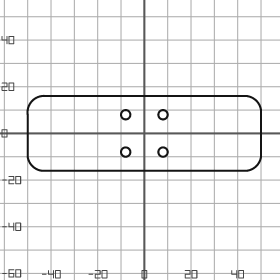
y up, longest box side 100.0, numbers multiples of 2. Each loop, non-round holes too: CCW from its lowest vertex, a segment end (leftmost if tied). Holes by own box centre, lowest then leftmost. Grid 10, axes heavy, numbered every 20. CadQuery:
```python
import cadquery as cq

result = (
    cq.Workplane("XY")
    .moveTo(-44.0, -16.0)
    .lineTo(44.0, -16.0)
    .threePointArc((48.0, -14.0), (50.0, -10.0))
    .lineTo(50.0, 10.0)
    .threePointArc((48.0, 14.0), (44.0, 16.0))
    .lineTo(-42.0, 16.0)
    .threePointArc((-48.0, 14.0), (-50.0, 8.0))
    .lineTo(-50.0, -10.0)
    .threePointArc((-48.0, -14.0), (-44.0, -16.0))
    .close()
    .moveTo(-8.0, -8.0)
    .circle(2.0)
    .moveTo(8.0, -8.0)
    .circle(2.0)
    .moveTo(-8.0, 8.0)
    .circle(2.0)
    .moveTo(8.0, 8.0)
    .circle(2.0)
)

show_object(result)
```